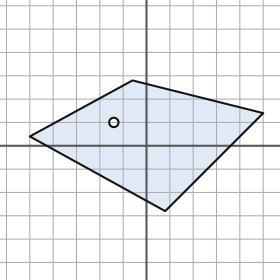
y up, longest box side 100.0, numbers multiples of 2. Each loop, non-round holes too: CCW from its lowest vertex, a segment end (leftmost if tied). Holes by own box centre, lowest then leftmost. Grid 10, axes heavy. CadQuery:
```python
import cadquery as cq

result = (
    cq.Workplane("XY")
    .moveTo(8.0, -28.0)
    .lineTo(50.0, 14.0)
    .lineTo(-6.0, 28.0)
    .lineTo(-50.0, 4.0)
    .close()
    .moveTo(-14.0, 10.0)
    .circle(2.0)
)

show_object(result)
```